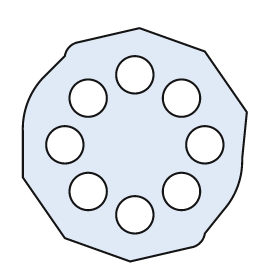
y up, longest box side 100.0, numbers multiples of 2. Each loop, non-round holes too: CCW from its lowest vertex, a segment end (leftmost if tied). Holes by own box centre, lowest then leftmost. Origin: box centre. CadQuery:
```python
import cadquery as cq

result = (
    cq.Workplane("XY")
    .moveTo(-2.0, -50.0)
    .lineTo(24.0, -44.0)
    .threePointArc((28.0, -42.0), (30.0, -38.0))
    .lineTo(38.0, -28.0)
    .threePointArc((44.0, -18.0), (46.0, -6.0))
    .lineTo(48.0, 14.0)
    .lineTo(30.0, 40.0)
    .lineTo(2.0, 50.0)
    .lineTo(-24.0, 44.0)
    .threePointArc((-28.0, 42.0), (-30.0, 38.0))
    .lineTo(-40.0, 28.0)
    .threePointArc((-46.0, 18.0), (-48.0, 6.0))
    .lineTo(-48.0, -14.0)
    .lineTo(-30.0, -40.0)
    .close()
    .moveTo(0.0, -30.0)
    .circle(8.0)
    .moveTo(-20.0, -20.0)
    .circle(8.0)
    .moveTo(20.0, -20.0)
    .circle(8.0)
    .moveTo(-30.0, 0.0)
    .circle(8.0)
    .moveTo(30.0, 0.0)
    .circle(8.0)
    .moveTo(-20.0, 20.0)
    .circle(8.0)
    .moveTo(20.0, 20.0)
    .circle(8.0)
    .moveTo(0.0, 30.0)
    .circle(8.0)
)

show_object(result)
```